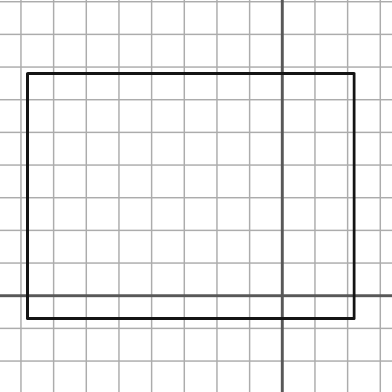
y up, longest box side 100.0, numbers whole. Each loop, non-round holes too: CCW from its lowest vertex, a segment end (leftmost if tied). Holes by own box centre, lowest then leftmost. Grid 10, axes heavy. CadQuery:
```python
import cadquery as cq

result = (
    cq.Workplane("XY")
    .moveTo(-78.0, -7.0)
    .lineTo(22.0, -7.0)
    .lineTo(22.0, 68.0)
    .lineTo(-78.0, 68.0)
    .close()
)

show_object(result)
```